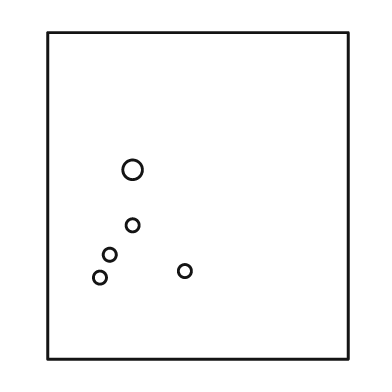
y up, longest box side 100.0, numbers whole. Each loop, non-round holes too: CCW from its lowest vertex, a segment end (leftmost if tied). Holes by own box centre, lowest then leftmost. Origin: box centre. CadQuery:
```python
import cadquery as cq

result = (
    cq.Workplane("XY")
    .moveTo(-46.0, -50.0)
    .lineTo(46.0, -50.0)
    .lineTo(46.0, 50.0)
    .lineTo(-46.0, 50.0)
    .close()
    .moveTo(-30.0, -25.0)
    .circle(2.0)
    .moveTo(-4.0, -23.0)
    .circle(2.0)
    .moveTo(-27.0, -18.0)
    .circle(2.0)
    .moveTo(-20.0, -9.0)
    .circle(2.0)
    .moveTo(-20.0, 8.0)
    .circle(3.0)
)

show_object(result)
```